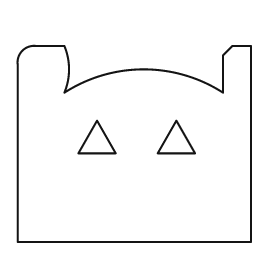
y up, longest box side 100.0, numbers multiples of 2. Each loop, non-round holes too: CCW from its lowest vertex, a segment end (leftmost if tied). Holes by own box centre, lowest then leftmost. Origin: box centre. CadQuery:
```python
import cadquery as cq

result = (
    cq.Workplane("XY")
    .moveTo(-50.0, -42.0)
    .lineTo(50.0, -42.0)
    .lineTo(50.0, 42.0)
    .lineTo(42.0, 42.0)
    .lineTo(38.0, 38.0)
    .lineTo(38.0, 22.0)
    .threePointArc((4.0, 32.0), (-30.0, 22.0))
    .threePointArc((-28.0, 32.0), (-30.0, 42.0))
    .lineTo(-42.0, 42.0)
    .threePointArc((-48.0, 40.0), (-50.0, 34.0))
    .close()
    .moveTo(-24.0, -4.0)
    .lineTo(-8.0, -4.0)
    .lineTo(-16.0, 10.0)
    .close()
    .moveTo(10.0, -4.0)
    .lineTo(26.0, -4.0)
    .lineTo(18.0, 10.0)
    .close()
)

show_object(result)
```